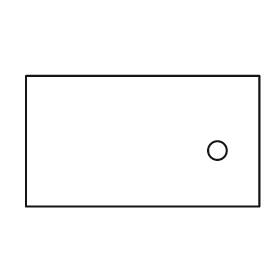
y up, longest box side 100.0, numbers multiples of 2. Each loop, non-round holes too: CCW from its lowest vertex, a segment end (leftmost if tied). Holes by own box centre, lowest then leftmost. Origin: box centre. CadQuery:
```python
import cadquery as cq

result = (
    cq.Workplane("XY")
    .moveTo(-50.0, -28.0)
    .lineTo(50.0, -28.0)
    .lineTo(50.0, 28.0)
    .lineTo(-50.0, 28.0)
    .close()
    .moveTo(32.0, -4.0)
    .circle(4.0)
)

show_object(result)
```